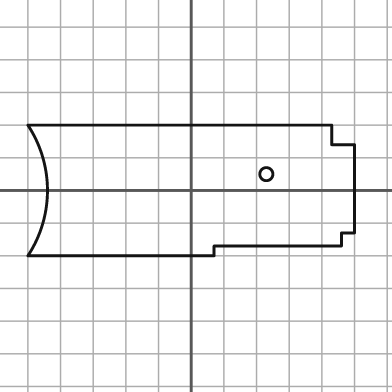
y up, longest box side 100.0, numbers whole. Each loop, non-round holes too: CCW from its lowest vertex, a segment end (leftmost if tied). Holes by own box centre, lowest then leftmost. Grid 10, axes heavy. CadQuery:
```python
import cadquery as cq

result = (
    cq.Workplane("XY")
    .moveTo(-50.0, -20.0)
    .lineTo(7.0, -20.0)
    .lineTo(7.0, -17.0)
    .lineTo(46.0, -17.0)
    .lineTo(46.0, -13.0)
    .lineTo(50.0, -13.0)
    .lineTo(50.0, 14.0)
    .lineTo(43.0, 14.0)
    .lineTo(43.0, 20.0)
    .lineTo(-50.0, 20.0)
    .threePointArc((-44.0, 0.0), (-50.0, -20.0))
    .close()
    .moveTo(23.0, 5.0)
    .circle(2.0)
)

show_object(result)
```